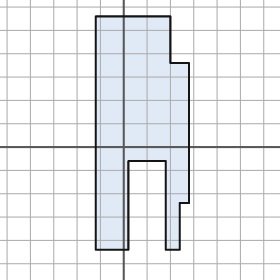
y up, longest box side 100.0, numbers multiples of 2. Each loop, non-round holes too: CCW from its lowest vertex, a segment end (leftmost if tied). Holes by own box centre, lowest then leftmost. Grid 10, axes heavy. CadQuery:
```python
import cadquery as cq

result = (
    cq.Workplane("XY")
    .moveTo(-12.0, -44.0)
    .lineTo(2.0, -44.0)
    .lineTo(2.0, -6.0)
    .lineTo(18.0, -6.0)
    .lineTo(18.0, -44.0)
    .lineTo(24.0, -44.0)
    .lineTo(24.0, -24.0)
    .lineTo(28.0, -24.0)
    .lineTo(28.0, 36.0)
    .lineTo(20.0, 36.0)
    .lineTo(20.0, 56.0)
    .lineTo(-12.0, 56.0)
    .close()
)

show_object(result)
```